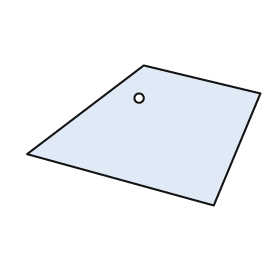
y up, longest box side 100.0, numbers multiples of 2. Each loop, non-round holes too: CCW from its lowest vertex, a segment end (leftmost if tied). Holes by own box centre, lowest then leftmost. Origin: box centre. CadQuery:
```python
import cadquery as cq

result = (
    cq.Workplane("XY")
    .moveTo(30.0, -30.0)
    .lineTo(50.0, 18.0)
    .lineTo(0.0, 30.0)
    .lineTo(-50.0, -8.0)
    .close()
    .moveTo(-2.0, 16.0)
    .circle(2.0)
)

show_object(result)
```